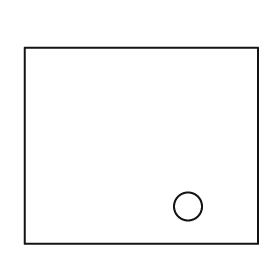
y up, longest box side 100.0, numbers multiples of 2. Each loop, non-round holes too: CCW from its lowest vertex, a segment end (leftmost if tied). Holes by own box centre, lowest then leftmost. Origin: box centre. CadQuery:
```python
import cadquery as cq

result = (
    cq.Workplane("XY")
    .moveTo(-50.0, -42.0)
    .lineTo(50.0, -42.0)
    .lineTo(50.0, 42.0)
    .lineTo(-50.0, 42.0)
    .close()
    .moveTo(20.0, -26.0)
    .circle(6.0)
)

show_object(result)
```